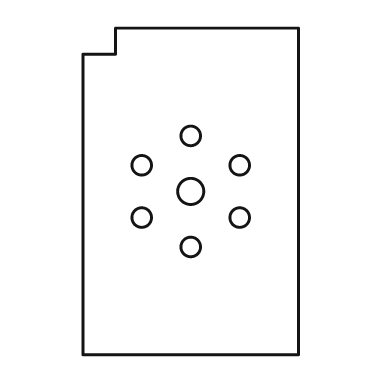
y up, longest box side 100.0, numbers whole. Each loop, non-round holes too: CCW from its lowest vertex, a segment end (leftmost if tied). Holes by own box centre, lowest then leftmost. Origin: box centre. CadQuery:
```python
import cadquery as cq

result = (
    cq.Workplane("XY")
    .moveTo(-33.0, -50.0)
    .lineTo(33.0, -50.0)
    .lineTo(33.0, 50.0)
    .lineTo(-23.0, 50.0)
    .lineTo(-23.0, 42.0)
    .lineTo(-33.0, 42.0)
    .close()
    .moveTo(0.0, -17.0)
    .circle(3.0)
    .moveTo(-15.0, -8.0)
    .circle(3.0)
    .moveTo(15.0, -8.0)
    .circle(3.0)
    .moveTo(0.0, 0.0)
    .circle(4.0)
    .moveTo(-15.0, 8.0)
    .circle(3.0)
    .moveTo(15.0, 8.0)
    .circle(3.0)
    .moveTo(0.0, 17.0)
    .circle(3.0)
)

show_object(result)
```